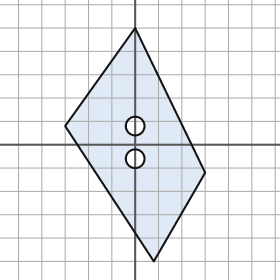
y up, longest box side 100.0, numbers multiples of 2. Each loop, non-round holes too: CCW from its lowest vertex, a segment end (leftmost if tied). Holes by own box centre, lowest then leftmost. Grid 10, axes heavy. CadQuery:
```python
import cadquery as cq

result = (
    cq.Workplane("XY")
    .moveTo(8.0, -50.0)
    .lineTo(30.0, -12.0)
    .lineTo(0.0, 50.0)
    .lineTo(-30.0, 8.0)
    .close()
    .moveTo(0.0, -6.0)
    .circle(4.0)
    .moveTo(0.0, 8.0)
    .circle(4.0)
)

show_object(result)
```